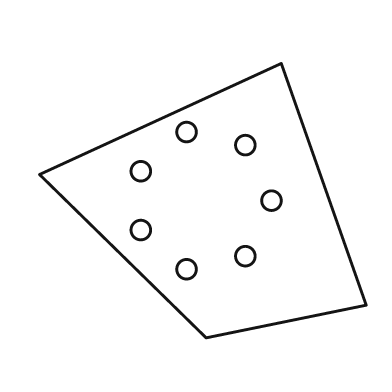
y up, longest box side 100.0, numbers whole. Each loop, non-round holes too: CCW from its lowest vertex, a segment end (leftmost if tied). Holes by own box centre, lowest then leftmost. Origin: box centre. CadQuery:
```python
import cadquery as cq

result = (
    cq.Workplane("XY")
    .moveTo(1.0, -42.0)
    .lineTo(50.0, -32.0)
    .lineTo(24.0, 42.0)
    .lineTo(-50.0, 8.0)
    .close()
    .moveTo(-5.0, -21.0)
    .circle(3.0)
    .moveTo(13.0, -17.0)
    .circle(3.0)
    .moveTo(-19.0, -9.0)
    .circle(3.0)
    .moveTo(21.0, 0.0)
    .circle(3.0)
    .moveTo(-19.0, 9.0)
    .circle(3.0)
    .moveTo(13.0, 17.0)
    .circle(3.0)
    .moveTo(-5.0, 21.0)
    .circle(3.0)
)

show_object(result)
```